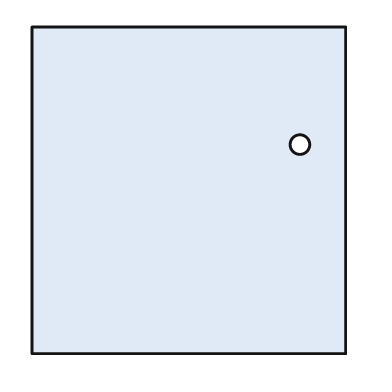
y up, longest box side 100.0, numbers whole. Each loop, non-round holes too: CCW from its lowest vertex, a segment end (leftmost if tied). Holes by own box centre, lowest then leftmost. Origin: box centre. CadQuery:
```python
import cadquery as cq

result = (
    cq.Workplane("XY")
    .moveTo(-48.0, -50.0)
    .lineTo(48.0, -50.0)
    .lineTo(48.0, 50.0)
    .lineTo(-48.0, 50.0)
    .close()
    .moveTo(34.0, 14.0)
    .circle(3.0)
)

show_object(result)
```